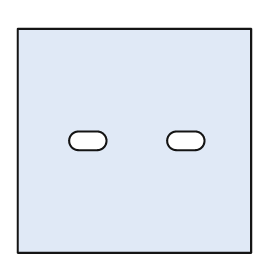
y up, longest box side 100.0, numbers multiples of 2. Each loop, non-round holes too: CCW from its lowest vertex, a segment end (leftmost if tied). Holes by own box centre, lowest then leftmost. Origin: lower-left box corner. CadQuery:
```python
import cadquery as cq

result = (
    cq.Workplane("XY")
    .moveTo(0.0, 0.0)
    .lineTo(100.0, 0.0)
    .lineTo(100.0, 96.0)
    .lineTo(0.0, 96.0)
    .close()
    .moveTo(26.0, 44.0)
    .lineTo(34.0, 44.0)
    .threePointArc((38.0, 48.0), (34.0, 52.0))
    .lineTo(26.0, 52.0)
    .threePointArc((22.0, 48.0), (26.0, 44.0))
    .close()
    .moveTo(68.0, 44.0)
    .lineTo(76.0, 44.0)
    .threePointArc((80.0, 48.0), (76.0, 52.0))
    .lineTo(68.0, 52.0)
    .threePointArc((64.0, 48.0), (68.0, 44.0))
    .close()
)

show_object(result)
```